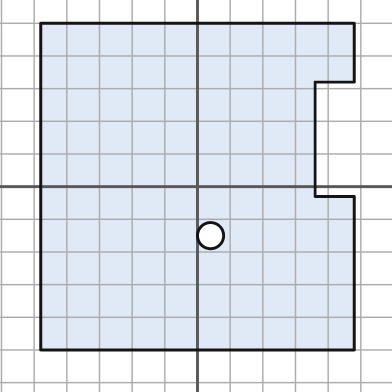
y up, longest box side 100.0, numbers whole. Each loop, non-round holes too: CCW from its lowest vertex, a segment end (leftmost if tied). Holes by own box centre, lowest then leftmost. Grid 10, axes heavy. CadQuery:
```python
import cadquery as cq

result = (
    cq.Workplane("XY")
    .moveTo(-48.0, -50.0)
    .lineTo(48.0, -50.0)
    .lineTo(48.0, -3.0)
    .lineTo(36.0, -3.0)
    .lineTo(36.0, 32.0)
    .lineTo(48.0, 32.0)
    .lineTo(48.0, 50.0)
    .lineTo(-48.0, 50.0)
    .close()
    .moveTo(4.0, -15.0)
    .circle(4.0)
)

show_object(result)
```